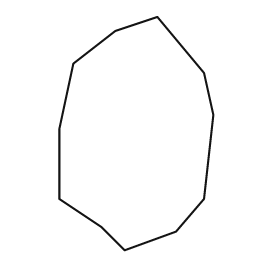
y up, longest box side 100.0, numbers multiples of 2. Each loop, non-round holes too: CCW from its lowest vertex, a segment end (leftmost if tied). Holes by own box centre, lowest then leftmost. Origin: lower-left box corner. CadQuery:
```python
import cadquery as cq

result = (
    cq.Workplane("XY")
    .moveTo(28.0, 0.0)
    .lineTo(50.0, 8.0)
    .lineTo(62.0, 22.0)
    .lineTo(66.0, 58.0)
    .lineTo(62.0, 76.0)
    .lineTo(42.0, 100.0)
    .lineTo(24.0, 94.0)
    .lineTo(6.0, 80.0)
    .lineTo(0.0, 52.0)
    .lineTo(0.0, 22.0)
    .lineTo(18.0, 10.0)
    .close()
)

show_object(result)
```